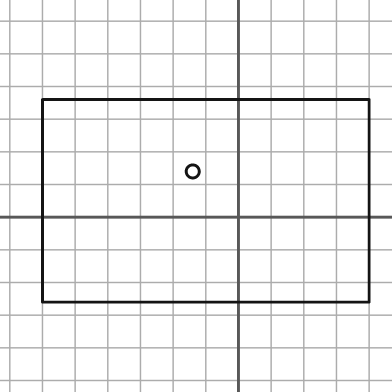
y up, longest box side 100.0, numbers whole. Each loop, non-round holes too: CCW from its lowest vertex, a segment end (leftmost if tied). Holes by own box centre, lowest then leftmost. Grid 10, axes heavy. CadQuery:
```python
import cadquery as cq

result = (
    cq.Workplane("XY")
    .moveTo(-60.0, -26.0)
    .lineTo(40.0, -26.0)
    .lineTo(40.0, 36.0)
    .lineTo(-60.0, 36.0)
    .close()
    .moveTo(-14.0, 14.0)
    .circle(2.0)
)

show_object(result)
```